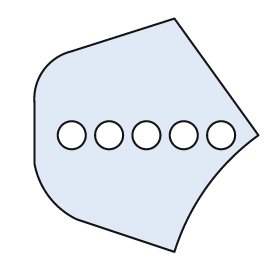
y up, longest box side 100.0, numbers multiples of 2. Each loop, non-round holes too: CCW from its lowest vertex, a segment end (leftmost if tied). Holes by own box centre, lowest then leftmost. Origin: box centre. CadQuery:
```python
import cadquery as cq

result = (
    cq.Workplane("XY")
    .moveTo(12.0, -50.0)
    .threePointArc((26.0, -22.0), (48.0, 0.0))
    .lineTo(12.0, 50.0)
    .lineTo(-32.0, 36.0)
    .threePointArc((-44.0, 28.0), (-48.0, 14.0))
    .lineTo(-48.0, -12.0)
    .threePointArc((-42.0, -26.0), (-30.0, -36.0))
    .close()
    .moveTo(-32.0, 0.0)
    .circle(6.0)
    .moveTo(-16.0, 0.0)
    .circle(6.0)
    .moveTo(0.0, 0.0)
    .circle(6.0)
    .moveTo(16.0, 0.0)
    .circle(6.0)
    .moveTo(32.0, 0.0)
    .circle(6.0)
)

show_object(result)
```